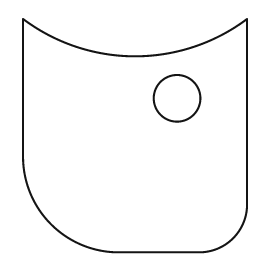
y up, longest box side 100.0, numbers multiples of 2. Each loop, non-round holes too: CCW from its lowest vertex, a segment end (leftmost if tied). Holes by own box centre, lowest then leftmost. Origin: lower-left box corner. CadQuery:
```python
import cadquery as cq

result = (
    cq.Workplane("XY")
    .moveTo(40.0, 0.0)
    .lineTo(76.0, 0.0)
    .threePointArc((90.0, 6.0), (96.0, 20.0))
    .lineTo(96.0, 100.0)
    .threePointArc((48.0, 84.0), (0.0, 100.0))
    .lineTo(0.0, 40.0)
    .threePointArc((12.0, 12.0), (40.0, 0.0))
    .close()
    .moveTo(66.0, 66.0)
    .circle(10.0)
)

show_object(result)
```